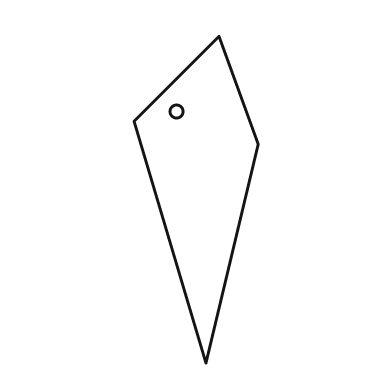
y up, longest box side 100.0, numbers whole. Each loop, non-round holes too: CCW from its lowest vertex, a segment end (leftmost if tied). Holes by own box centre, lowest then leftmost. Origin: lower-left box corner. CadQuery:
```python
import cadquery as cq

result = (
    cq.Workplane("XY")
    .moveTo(22.0, 0.0)
    .lineTo(38.0, 67.0)
    .lineTo(26.0, 100.0)
    .lineTo(0.0, 74.0)
    .close()
    .moveTo(13.0, 77.0)
    .circle(2.0)
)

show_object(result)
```